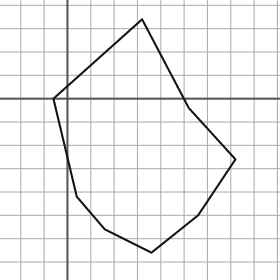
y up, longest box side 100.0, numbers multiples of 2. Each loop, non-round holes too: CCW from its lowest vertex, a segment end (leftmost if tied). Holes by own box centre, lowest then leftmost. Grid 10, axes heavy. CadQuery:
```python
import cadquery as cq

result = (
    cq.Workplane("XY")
    .moveTo(36.0, -66.0)
    .lineTo(56.0, -50.0)
    .lineTo(72.0, -26.0)
    .lineTo(52.0, -4.0)
    .lineTo(32.0, 34.0)
    .lineTo(-6.0, 0.0)
    .lineTo(4.0, -42.0)
    .lineTo(16.0, -56.0)
    .close()
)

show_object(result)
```